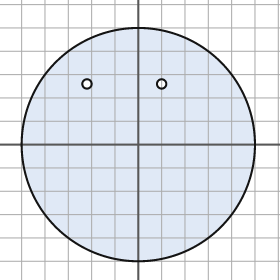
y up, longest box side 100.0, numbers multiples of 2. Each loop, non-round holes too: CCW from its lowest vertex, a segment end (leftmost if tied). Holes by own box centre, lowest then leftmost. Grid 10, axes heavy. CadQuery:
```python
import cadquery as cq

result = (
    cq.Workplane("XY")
    .moveTo(0.0, 0.0)
    .circle(50.0)
    .moveTo(-22.0, 26.0)
    .circle(2.0)
    .moveTo(10.0, 26.0)
    .circle(2.0)
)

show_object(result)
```